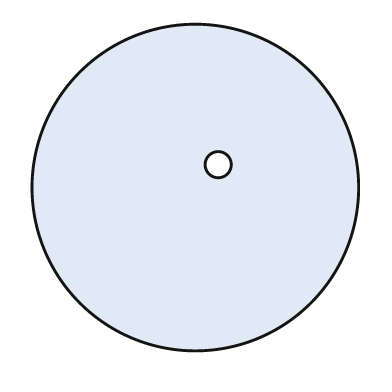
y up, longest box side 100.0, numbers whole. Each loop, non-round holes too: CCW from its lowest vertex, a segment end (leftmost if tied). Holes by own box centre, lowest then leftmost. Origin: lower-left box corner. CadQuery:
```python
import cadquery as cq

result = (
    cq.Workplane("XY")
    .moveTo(50.0, 50.0)
    .circle(50.0)
    .moveTo(57.0, 57.0)
    .circle(4.0)
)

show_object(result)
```